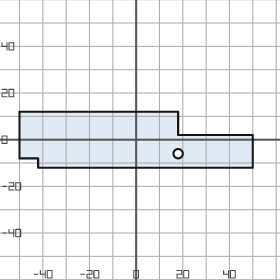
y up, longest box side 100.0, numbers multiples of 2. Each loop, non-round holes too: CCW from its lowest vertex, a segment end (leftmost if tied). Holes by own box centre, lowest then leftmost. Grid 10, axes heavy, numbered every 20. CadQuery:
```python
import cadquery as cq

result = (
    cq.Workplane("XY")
    .moveTo(-42.0, -12.0)
    .lineTo(50.0, -12.0)
    .lineTo(50.0, 2.0)
    .lineTo(18.0, 2.0)
    .lineTo(18.0, 12.0)
    .lineTo(-50.0, 12.0)
    .lineTo(-50.0, -8.0)
    .lineTo(-42.0, -8.0)
    .close()
    .moveTo(18.0, -6.0)
    .circle(2.0)
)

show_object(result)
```